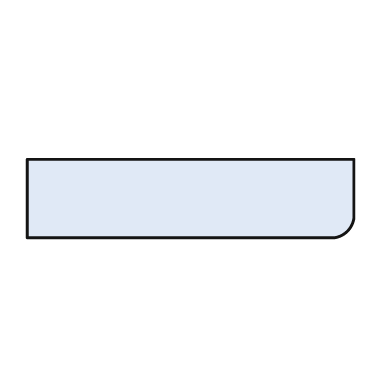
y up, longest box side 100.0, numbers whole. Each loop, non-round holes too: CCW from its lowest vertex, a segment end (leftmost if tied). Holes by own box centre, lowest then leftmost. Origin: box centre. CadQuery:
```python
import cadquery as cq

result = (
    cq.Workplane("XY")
    .moveTo(-50.0, -12.0)
    .lineTo(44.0, -12.0)
    .threePointArc((48.0, -10.0), (50.0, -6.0))
    .lineTo(50.0, 12.0)
    .lineTo(-50.0, 12.0)
    .close()
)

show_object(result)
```